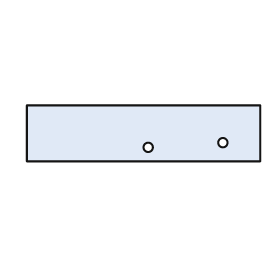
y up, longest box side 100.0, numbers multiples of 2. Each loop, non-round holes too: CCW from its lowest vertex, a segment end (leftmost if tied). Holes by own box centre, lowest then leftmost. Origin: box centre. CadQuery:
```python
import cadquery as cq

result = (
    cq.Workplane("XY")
    .moveTo(-50.0, -12.0)
    .lineTo(50.0, -12.0)
    .lineTo(50.0, 12.0)
    .lineTo(-50.0, 12.0)
    .close()
    .moveTo(2.0, -6.0)
    .circle(2.0)
    .moveTo(34.0, -4.0)
    .circle(2.0)
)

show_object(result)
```